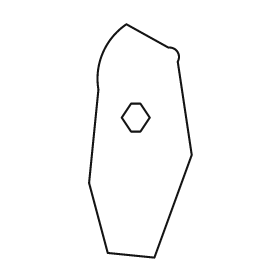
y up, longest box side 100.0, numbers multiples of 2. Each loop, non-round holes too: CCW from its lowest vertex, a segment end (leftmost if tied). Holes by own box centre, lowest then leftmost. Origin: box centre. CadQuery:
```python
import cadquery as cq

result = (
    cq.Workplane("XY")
    .moveTo(6.0, -50.0)
    .lineTo(22.0, -6.0)
    .lineTo(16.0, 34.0)
    .threePointArc((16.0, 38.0), (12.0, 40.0))
    .lineTo(-6.0, 50.0)
    .threePointArc((-16.0, 38.0), (-18.0, 22.0))
    .lineTo(-22.0, -18.0)
    .lineTo(-14.0, -48.0)
    .close()
    .moveTo(-4.0, 4.0)
    .lineTo(0.0, 4.0)
    .lineTo(4.0, 10.0)
    .lineTo(0.0, 16.0)
    .lineTo(-4.0, 16.0)
    .lineTo(-8.0, 10.0)
    .close()
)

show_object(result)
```